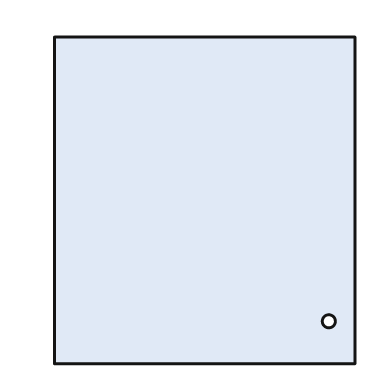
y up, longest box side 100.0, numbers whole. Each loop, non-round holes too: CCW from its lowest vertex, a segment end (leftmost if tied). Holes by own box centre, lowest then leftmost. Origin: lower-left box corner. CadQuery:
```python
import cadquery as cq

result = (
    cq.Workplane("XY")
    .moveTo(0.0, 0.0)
    .lineTo(92.0, 0.0)
    .lineTo(92.0, 100.0)
    .lineTo(0.0, 100.0)
    .close()
    .moveTo(84.0, 13.0)
    .circle(2.0)
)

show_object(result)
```